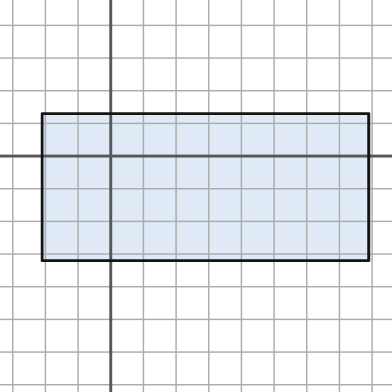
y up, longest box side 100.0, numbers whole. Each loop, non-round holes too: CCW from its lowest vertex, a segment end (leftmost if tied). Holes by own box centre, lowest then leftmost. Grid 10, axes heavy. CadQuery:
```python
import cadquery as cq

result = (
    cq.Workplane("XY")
    .moveTo(-21.0, -32.0)
    .lineTo(79.0, -32.0)
    .lineTo(79.0, 13.0)
    .lineTo(-21.0, 13.0)
    .close()
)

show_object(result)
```